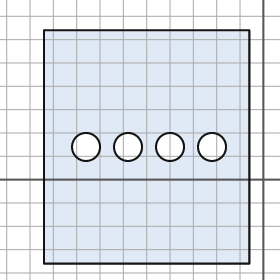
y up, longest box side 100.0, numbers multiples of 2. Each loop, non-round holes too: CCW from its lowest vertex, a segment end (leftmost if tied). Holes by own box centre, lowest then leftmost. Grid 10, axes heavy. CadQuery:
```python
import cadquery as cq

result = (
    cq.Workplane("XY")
    .moveTo(-94.0, -36.0)
    .lineTo(-6.0, -36.0)
    .lineTo(-6.0, 64.0)
    .lineTo(-94.0, 64.0)
    .close()
    .moveTo(-76.0, 14.0)
    .circle(6.0)
    .moveTo(-58.0, 14.0)
    .circle(6.0)
    .moveTo(-40.0, 14.0)
    .circle(6.0)
    .moveTo(-22.0, 14.0)
    .circle(6.0)
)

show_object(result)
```